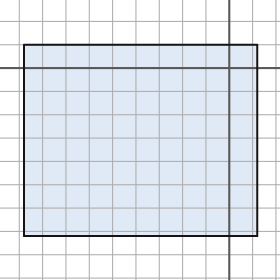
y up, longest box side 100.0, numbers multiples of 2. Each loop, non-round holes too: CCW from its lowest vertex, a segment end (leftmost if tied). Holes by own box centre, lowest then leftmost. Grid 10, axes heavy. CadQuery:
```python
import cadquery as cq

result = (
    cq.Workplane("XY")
    .moveTo(-88.0, -72.0)
    .lineTo(12.0, -72.0)
    .lineTo(12.0, 10.0)
    .lineTo(-88.0, 10.0)
    .close()
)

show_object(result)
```